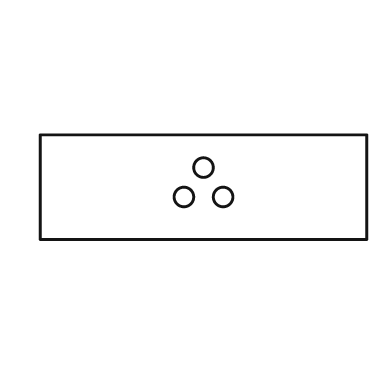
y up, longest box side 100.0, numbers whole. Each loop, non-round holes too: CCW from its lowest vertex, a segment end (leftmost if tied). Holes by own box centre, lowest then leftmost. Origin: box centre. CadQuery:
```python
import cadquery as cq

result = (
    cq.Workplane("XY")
    .moveTo(-50.0, -16.0)
    .lineTo(50.0, -16.0)
    .lineTo(50.0, 16.0)
    .lineTo(-50.0, 16.0)
    .close()
    .moveTo(-6.0, -3.0)
    .circle(3.0)
    .moveTo(6.0, -3.0)
    .circle(3.0)
    .moveTo(0.0, 6.0)
    .circle(3.0)
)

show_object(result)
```